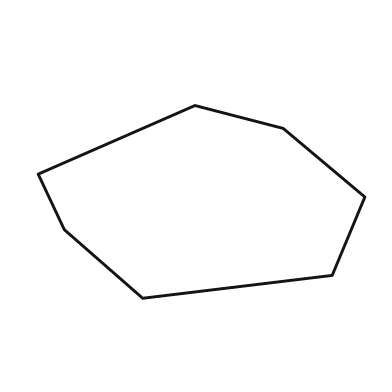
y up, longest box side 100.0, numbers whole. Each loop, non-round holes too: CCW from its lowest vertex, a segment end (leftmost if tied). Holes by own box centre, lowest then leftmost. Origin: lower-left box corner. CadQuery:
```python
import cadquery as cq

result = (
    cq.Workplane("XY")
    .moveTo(32.0, 0.0)
    .lineTo(90.0, 7.0)
    .lineTo(100.0, 31.0)
    .lineTo(75.0, 52.0)
    .lineTo(48.0, 59.0)
    .lineTo(0.0, 38.0)
    .lineTo(8.0, 21.0)
    .close()
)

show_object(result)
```